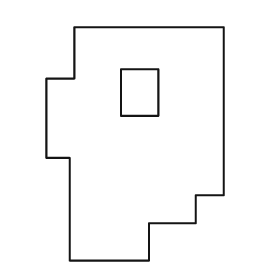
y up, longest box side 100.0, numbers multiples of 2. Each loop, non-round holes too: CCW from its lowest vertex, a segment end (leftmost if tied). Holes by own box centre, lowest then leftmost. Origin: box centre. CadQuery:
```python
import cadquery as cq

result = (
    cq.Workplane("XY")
    .moveTo(-28.0, -50.0)
    .lineTo(6.0, -50.0)
    .lineTo(6.0, -34.0)
    .lineTo(26.0, -34.0)
    .lineTo(26.0, -22.0)
    .lineTo(38.0, -22.0)
    .lineTo(38.0, 50.0)
    .lineTo(-26.0, 50.0)
    .lineTo(-26.0, 28.0)
    .lineTo(-38.0, 28.0)
    .lineTo(-38.0, -6.0)
    .lineTo(-28.0, -6.0)
    .close()
    .moveTo(-6.0, 12.0)
    .lineTo(10.0, 12.0)
    .lineTo(10.0, 32.0)
    .lineTo(-6.0, 32.0)
    .close()
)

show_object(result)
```